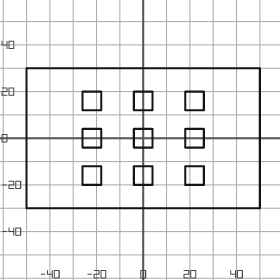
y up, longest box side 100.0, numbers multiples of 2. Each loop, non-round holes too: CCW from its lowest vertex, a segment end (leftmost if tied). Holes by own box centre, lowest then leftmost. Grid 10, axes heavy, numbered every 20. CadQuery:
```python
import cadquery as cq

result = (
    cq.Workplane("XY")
    .moveTo(-50.0, -30.0)
    .lineTo(50.0, -30.0)
    .lineTo(50.0, 30.0)
    .lineTo(-50.0, 30.0)
    .close()
    .moveTo(-26.0, -20.0)
    .lineTo(-18.0, -20.0)
    .lineTo(-18.0, -12.0)
    .lineTo(-26.0, -12.0)
    .close()
    .moveTo(-4.0, -20.0)
    .lineTo(4.0, -20.0)
    .lineTo(4.0, -12.0)
    .lineTo(-4.0, -12.0)
    .close()
    .moveTo(18.0, -20.0)
    .lineTo(26.0, -20.0)
    .lineTo(26.0, -12.0)
    .lineTo(18.0, -12.0)
    .close()
    .moveTo(-26.0, -4.0)
    .lineTo(-18.0, -4.0)
    .lineTo(-18.0, 4.0)
    .lineTo(-26.0, 4.0)
    .close()
    .moveTo(-4.0, -4.0)
    .lineTo(4.0, -4.0)
    .lineTo(4.0, 4.0)
    .lineTo(-4.0, 4.0)
    .close()
    .moveTo(18.0, -4.0)
    .lineTo(26.0, -4.0)
    .lineTo(26.0, 4.0)
    .lineTo(18.0, 4.0)
    .close()
    .moveTo(-26.0, 12.0)
    .lineTo(-18.0, 12.0)
    .lineTo(-18.0, 20.0)
    .lineTo(-26.0, 20.0)
    .close()
    .moveTo(-4.0, 12.0)
    .lineTo(4.0, 12.0)
    .lineTo(4.0, 20.0)
    .lineTo(-4.0, 20.0)
    .close()
    .moveTo(18.0, 12.0)
    .lineTo(26.0, 12.0)
    .lineTo(26.0, 20.0)
    .lineTo(18.0, 20.0)
    .close()
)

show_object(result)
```